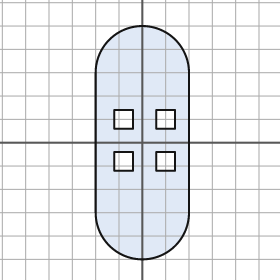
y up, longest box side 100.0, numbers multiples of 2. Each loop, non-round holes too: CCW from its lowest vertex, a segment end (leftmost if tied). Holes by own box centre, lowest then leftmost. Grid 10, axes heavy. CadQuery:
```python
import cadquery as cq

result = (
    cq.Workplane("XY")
    .moveTo(-20.0, -30.0)
    .threePointArc((0.0, -50.0), (20.0, -30.0))
    .lineTo(20.0, 30.0)
    .threePointArc((0.0, 50.0), (-20.0, 30.0))
    .close()
    .moveTo(-12.0, -12.0)
    .lineTo(-4.0, -12.0)
    .lineTo(-4.0, -4.0)
    .lineTo(-12.0, -4.0)
    .close()
    .moveTo(6.0, -12.0)
    .lineTo(14.0, -12.0)
    .lineTo(14.0, -4.0)
    .lineTo(6.0, -4.0)
    .close()
    .moveTo(-12.0, 6.0)
    .lineTo(-4.0, 6.0)
    .lineTo(-4.0, 14.0)
    .lineTo(-12.0, 14.0)
    .close()
    .moveTo(6.0, 6.0)
    .lineTo(14.0, 6.0)
    .lineTo(14.0, 14.0)
    .lineTo(6.0, 14.0)
    .close()
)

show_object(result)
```